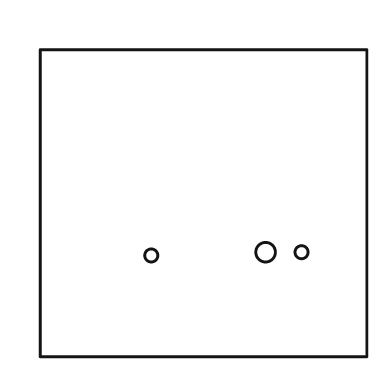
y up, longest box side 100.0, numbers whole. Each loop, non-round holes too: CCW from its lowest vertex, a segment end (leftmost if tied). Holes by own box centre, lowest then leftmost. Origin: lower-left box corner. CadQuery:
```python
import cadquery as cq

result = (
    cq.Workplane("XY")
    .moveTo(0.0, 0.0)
    .lineTo(100.0, 0.0)
    .lineTo(100.0, 94.0)
    .lineTo(0.0, 94.0)
    .close()
    .moveTo(34.0, 31.0)
    .circle(2.0)
    .moveTo(69.0, 32.0)
    .circle(3.0)
    .moveTo(80.0, 32.0)
    .circle(2.0)
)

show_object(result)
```